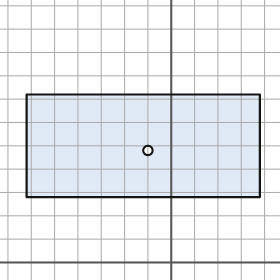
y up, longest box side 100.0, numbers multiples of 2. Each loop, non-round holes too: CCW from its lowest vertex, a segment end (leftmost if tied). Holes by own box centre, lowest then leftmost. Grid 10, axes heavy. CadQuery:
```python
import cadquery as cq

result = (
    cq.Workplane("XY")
    .moveTo(-62.0, 28.0)
    .lineTo(38.0, 28.0)
    .lineTo(38.0, 72.0)
    .lineTo(-62.0, 72.0)
    .close()
    .moveTo(-10.0, 48.0)
    .circle(2.0)
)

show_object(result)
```